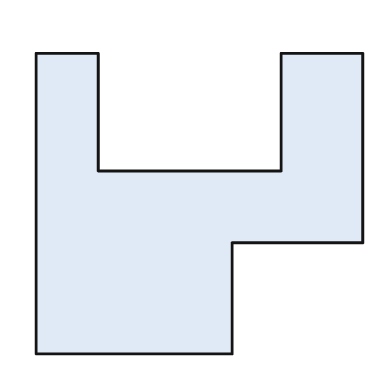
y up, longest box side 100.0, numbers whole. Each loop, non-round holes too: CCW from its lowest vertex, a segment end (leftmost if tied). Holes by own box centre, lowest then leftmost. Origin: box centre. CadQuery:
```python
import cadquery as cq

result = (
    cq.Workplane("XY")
    .moveTo(-50.0, -46.0)
    .lineTo(10.0, -46.0)
    .lineTo(10.0, -12.0)
    .lineTo(50.0, -12.0)
    .lineTo(50.0, 46.0)
    .lineTo(25.0, 46.0)
    .lineTo(25.0, 10.0)
    .lineTo(-31.0, 10.0)
    .lineTo(-31.0, 46.0)
    .lineTo(-50.0, 46.0)
    .close()
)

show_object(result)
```